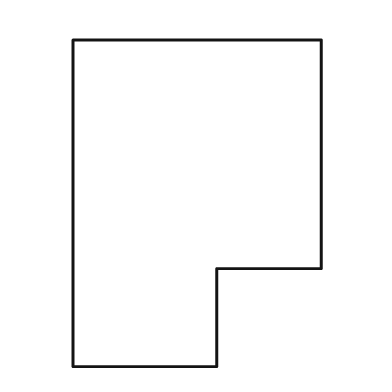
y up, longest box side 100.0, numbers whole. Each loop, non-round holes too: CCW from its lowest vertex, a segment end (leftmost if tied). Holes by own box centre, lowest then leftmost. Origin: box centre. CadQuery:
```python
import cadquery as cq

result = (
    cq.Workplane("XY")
    .moveTo(-38.0, -50.0)
    .lineTo(6.0, -50.0)
    .lineTo(6.0, -20.0)
    .lineTo(38.0, -20.0)
    .lineTo(38.0, 50.0)
    .lineTo(-38.0, 50.0)
    .close()
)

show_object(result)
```